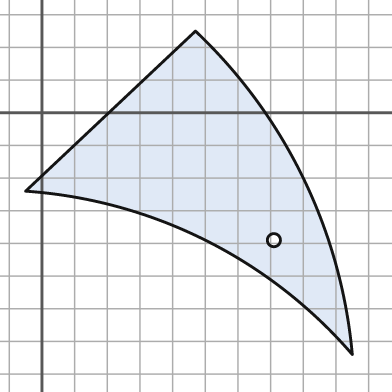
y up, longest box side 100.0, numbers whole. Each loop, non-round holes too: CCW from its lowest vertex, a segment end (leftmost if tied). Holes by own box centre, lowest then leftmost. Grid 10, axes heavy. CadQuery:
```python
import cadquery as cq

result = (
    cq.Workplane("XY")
    .moveTo(95.0, -74.0)
    .threePointArc((80.0, -20.0), (47.0, 25.0))
    .lineTo(-5.0, -24.0)
    .threePointArc((50.0, -39.0), (95.0, -74.0))
    .close()
    .moveTo(71.0, -39.0)
    .circle(2.0)
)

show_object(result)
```